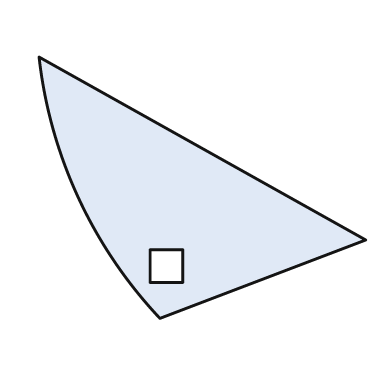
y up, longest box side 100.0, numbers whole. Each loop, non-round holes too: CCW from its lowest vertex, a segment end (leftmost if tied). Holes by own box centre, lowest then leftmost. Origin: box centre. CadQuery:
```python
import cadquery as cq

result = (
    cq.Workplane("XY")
    .moveTo(-13.0, -40.0)
    .lineTo(50.0, -16.0)
    .lineTo(-50.0, 40.0)
    .threePointArc((-38.0, -3.0), (-13.0, -40.0))
    .close()
    .moveTo(-16.0, -29.0)
    .lineTo(-6.0, -29.0)
    .lineTo(-6.0, -19.0)
    .lineTo(-16.0, -19.0)
    .close()
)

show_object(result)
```